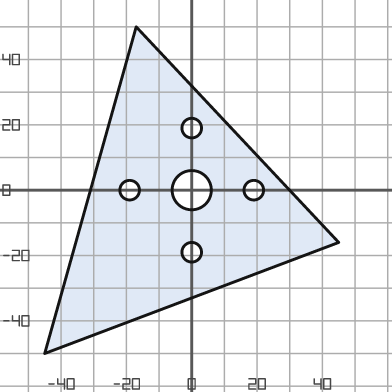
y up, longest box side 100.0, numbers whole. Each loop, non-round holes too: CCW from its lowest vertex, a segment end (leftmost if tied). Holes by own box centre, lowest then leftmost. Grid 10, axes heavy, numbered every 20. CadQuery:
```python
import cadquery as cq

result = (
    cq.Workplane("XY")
    .moveTo(-45.0, -50.0)
    .lineTo(45.0, -16.0)
    .lineTo(-17.0, 50.0)
    .close()
    .moveTo(0.0, -19.0)
    .circle(3.0)
    .moveTo(-19.0, 0.0)
    .circle(3.0)
    .moveTo(0.0, 0.0)
    .circle(6.0)
    .moveTo(19.0, 0.0)
    .circle(3.0)
    .moveTo(0.0, 19.0)
    .circle(3.0)
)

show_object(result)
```